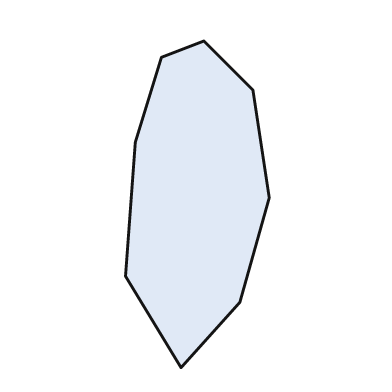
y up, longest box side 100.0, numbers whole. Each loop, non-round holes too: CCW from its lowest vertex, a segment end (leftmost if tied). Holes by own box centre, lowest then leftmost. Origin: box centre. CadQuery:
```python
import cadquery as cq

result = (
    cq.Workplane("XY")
    .moveTo(-5.0, -50.0)
    .lineTo(13.0, -30.0)
    .lineTo(22.0, 2.0)
    .lineTo(17.0, 35.0)
    .lineTo(2.0, 50.0)
    .lineTo(-11.0, 45.0)
    .lineTo(-19.0, 19.0)
    .lineTo(-22.0, -22.0)
    .close()
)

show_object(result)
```